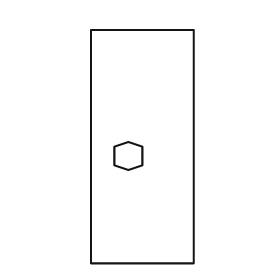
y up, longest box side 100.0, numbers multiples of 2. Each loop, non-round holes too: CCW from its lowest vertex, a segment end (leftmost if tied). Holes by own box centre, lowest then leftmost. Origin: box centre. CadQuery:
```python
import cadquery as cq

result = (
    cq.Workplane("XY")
    .moveTo(-22.0, -50.0)
    .lineTo(22.0, -50.0)
    .lineTo(22.0, 50.0)
    .lineTo(-22.0, 50.0)
    .close()
    .moveTo(-6.0, -10.0)
    .lineTo(0.0, -8.0)
    .lineTo(0.0, 0.0)
    .lineTo(-6.0, 2.0)
    .lineTo(-12.0, 0.0)
    .lineTo(-12.0, -8.0)
    .close()
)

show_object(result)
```